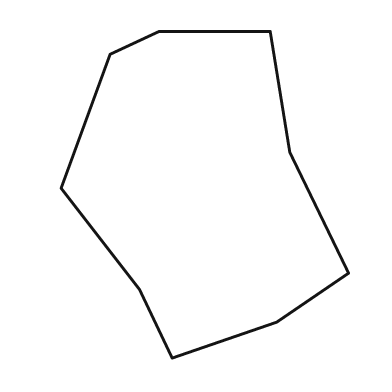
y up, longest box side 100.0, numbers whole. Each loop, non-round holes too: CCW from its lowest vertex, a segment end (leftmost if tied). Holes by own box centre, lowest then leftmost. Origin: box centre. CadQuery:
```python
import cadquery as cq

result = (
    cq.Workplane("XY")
    .moveTo(-10.0, -50.0)
    .lineTo(22.0, -39.0)
    .lineTo(44.0, -24.0)
    .lineTo(26.0, 13.0)
    .lineTo(20.0, 50.0)
    .lineTo(-14.0, 50.0)
    .lineTo(-29.0, 43.0)
    .lineTo(-44.0, 2.0)
    .lineTo(-20.0, -29.0)
    .close()
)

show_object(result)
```